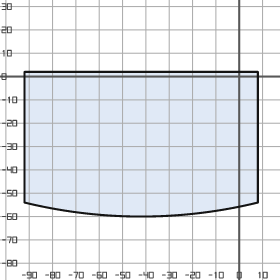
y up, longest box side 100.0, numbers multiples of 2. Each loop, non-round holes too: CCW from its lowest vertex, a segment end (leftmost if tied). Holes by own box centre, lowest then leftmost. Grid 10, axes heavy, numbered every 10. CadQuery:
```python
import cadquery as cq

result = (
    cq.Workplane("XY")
    .moveTo(-92.0, -54.0)
    .threePointArc((-42.0, -60.0), (8.0, -54.0))
    .lineTo(8.0, 2.0)
    .lineTo(-92.0, 2.0)
    .close()
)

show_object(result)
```